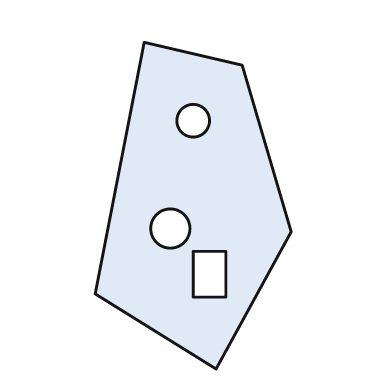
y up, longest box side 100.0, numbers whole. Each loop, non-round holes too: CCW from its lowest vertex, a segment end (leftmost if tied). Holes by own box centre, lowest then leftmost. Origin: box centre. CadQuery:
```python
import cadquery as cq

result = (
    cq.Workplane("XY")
    .moveTo(7.0, -50.0)
    .lineTo(30.0, -8.0)
    .lineTo(15.0, 43.0)
    .lineTo(-15.0, 50.0)
    .lineTo(-30.0, -27.0)
    .close()
    .moveTo(0.0, -28.0)
    .lineTo(10.0, -28.0)
    .lineTo(10.0, -14.0)
    .lineTo(0.0, -14.0)
    .close()
    .moveTo(-7.0, -7.0)
    .circle(6.0)
    .moveTo(0.0, 26.0)
    .circle(5.0)
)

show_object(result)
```